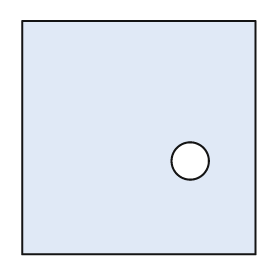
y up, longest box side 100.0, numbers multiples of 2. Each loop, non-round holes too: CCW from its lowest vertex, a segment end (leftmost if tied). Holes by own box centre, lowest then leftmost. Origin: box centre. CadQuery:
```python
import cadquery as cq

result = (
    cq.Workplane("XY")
    .moveTo(-50.0, -50.0)
    .lineTo(50.0, -50.0)
    .lineTo(50.0, 50.0)
    .lineTo(-50.0, 50.0)
    .close()
    .moveTo(22.0, -10.0)
    .circle(8.0)
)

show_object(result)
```